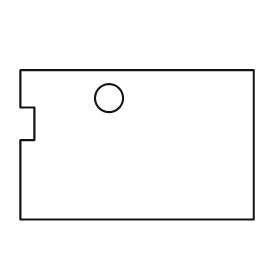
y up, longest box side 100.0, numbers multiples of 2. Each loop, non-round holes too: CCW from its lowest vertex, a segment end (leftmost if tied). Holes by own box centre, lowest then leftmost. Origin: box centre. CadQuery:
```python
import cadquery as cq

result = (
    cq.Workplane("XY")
    .moveTo(-50.0, -32.0)
    .lineTo(50.0, -32.0)
    .lineTo(50.0, 32.0)
    .lineTo(-50.0, 32.0)
    .lineTo(-50.0, 16.0)
    .lineTo(-44.0, 16.0)
    .lineTo(-44.0, 2.0)
    .lineTo(-50.0, 2.0)
    .close()
    .moveTo(-12.0, 20.0)
    .circle(6.0)
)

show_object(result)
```